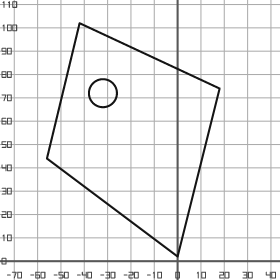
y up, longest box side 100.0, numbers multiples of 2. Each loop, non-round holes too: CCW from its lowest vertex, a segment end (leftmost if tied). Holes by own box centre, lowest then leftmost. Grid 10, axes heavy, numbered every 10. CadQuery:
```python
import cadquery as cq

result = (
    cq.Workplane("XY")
    .moveTo(0.0, 2.0)
    .lineTo(18.0, 74.0)
    .lineTo(-42.0, 102.0)
    .lineTo(-56.0, 44.0)
    .close()
    .moveTo(-32.0, 72.0)
    .circle(6.0)
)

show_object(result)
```